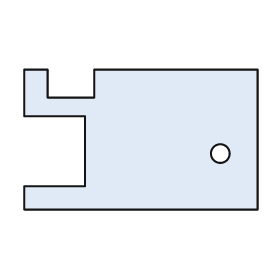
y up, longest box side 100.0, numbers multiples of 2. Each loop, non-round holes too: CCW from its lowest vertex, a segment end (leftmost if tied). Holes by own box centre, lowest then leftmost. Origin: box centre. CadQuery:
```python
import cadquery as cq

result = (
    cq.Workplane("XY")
    .moveTo(-50.0, -30.0)
    .lineTo(50.0, -30.0)
    .lineTo(50.0, 30.0)
    .lineTo(-20.0, 30.0)
    .lineTo(-20.0, 18.0)
    .lineTo(-40.0, 18.0)
    .lineTo(-40.0, 30.0)
    .lineTo(-50.0, 30.0)
    .lineTo(-50.0, 10.0)
    .lineTo(-24.0, 10.0)
    .lineTo(-24.0, -20.0)
    .lineTo(-50.0, -20.0)
    .close()
    .moveTo(34.0, -6.0)
    .circle(4.0)
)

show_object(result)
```